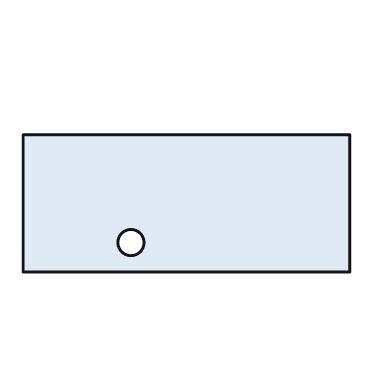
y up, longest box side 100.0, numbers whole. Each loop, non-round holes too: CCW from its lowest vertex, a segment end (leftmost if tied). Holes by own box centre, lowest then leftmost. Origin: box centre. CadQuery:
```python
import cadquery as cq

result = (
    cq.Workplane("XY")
    .moveTo(-50.0, -21.0)
    .lineTo(50.0, -21.0)
    .lineTo(50.0, 21.0)
    .lineTo(-50.0, 21.0)
    .close()
    .moveTo(-17.0, -12.0)
    .circle(4.0)
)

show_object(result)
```